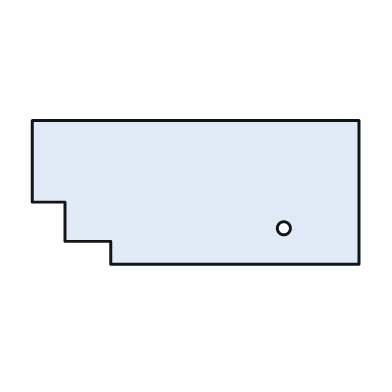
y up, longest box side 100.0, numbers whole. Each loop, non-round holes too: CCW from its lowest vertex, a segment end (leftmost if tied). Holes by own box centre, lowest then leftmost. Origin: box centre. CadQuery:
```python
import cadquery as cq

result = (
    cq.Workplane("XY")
    .moveTo(-26.0, -22.0)
    .lineTo(50.0, -22.0)
    .lineTo(50.0, 22.0)
    .lineTo(-50.0, 22.0)
    .lineTo(-50.0, -3.0)
    .lineTo(-40.0, -3.0)
    .lineTo(-40.0, -15.0)
    .lineTo(-26.0, -15.0)
    .close()
    .moveTo(27.0, -11.0)
    .circle(2.0)
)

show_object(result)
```